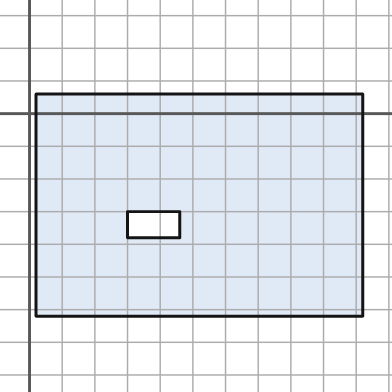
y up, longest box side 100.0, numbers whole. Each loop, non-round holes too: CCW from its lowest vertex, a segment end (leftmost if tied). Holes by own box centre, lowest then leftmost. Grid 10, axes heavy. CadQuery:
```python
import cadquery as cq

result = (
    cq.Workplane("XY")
    .moveTo(2.0, -62.0)
    .lineTo(102.0, -62.0)
    .lineTo(102.0, 6.0)
    .lineTo(2.0, 6.0)
    .close()
    .moveTo(30.0, -38.0)
    .lineTo(46.0, -38.0)
    .lineTo(46.0, -30.0)
    .lineTo(30.0, -30.0)
    .close()
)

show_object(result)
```